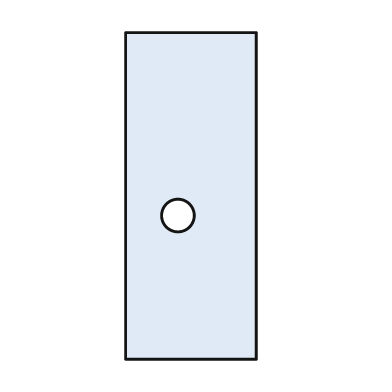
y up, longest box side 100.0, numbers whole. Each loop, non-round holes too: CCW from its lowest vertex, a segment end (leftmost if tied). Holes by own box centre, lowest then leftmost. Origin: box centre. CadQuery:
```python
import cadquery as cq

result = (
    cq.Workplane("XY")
    .moveTo(-20.0, -50.0)
    .lineTo(20.0, -50.0)
    .lineTo(20.0, 50.0)
    .lineTo(-20.0, 50.0)
    .close()
    .moveTo(-4.0, -6.0)
    .circle(5.0)
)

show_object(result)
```